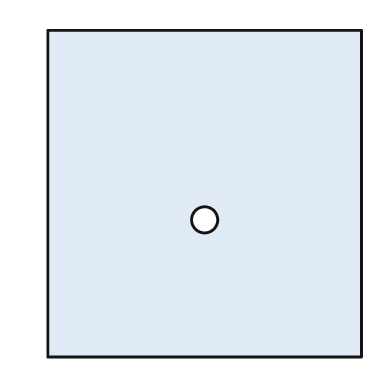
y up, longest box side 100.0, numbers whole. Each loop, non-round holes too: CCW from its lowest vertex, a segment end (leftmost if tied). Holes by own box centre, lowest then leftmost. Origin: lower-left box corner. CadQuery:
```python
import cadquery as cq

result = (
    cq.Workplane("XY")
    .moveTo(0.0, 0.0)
    .lineTo(96.0, 0.0)
    .lineTo(96.0, 100.0)
    .lineTo(0.0, 100.0)
    .close()
    .moveTo(48.0, 42.0)
    .circle(4.0)
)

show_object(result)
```